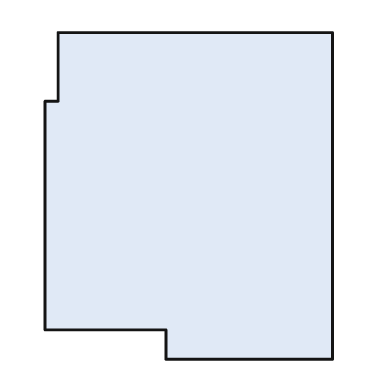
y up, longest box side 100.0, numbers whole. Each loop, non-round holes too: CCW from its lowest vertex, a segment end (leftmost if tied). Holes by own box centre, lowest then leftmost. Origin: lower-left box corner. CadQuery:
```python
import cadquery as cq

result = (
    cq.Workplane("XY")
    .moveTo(37.0, 0.0)
    .lineTo(88.0, 0.0)
    .lineTo(88.0, 100.0)
    .lineTo(4.0, 100.0)
    .lineTo(4.0, 79.0)
    .lineTo(0.0, 79.0)
    .lineTo(0.0, 9.0)
    .lineTo(37.0, 9.0)
    .close()
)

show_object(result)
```